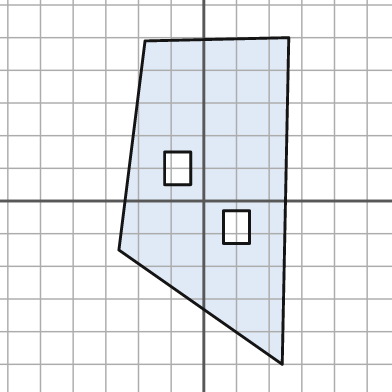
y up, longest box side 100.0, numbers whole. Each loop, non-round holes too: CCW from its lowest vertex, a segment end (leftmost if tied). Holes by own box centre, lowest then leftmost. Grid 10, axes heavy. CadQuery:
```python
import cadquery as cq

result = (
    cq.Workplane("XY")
    .moveTo(24.0, -50.0)
    .lineTo(26.0, 50.0)
    .lineTo(-18.0, 49.0)
    .lineTo(-26.0, -15.0)
    .close()
    .moveTo(6.0, -13.0)
    .lineTo(14.0, -13.0)
    .lineTo(14.0, -3.0)
    .lineTo(6.0, -3.0)
    .close()
    .moveTo(-12.0, 5.0)
    .lineTo(-4.0, 5.0)
    .lineTo(-4.0, 15.0)
    .lineTo(-12.0, 15.0)
    .close()
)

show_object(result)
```